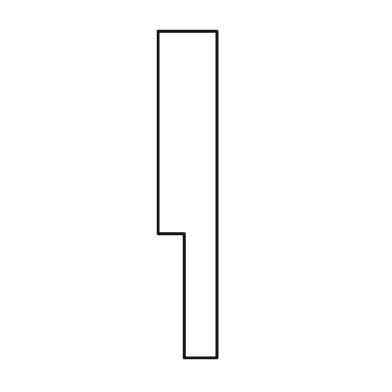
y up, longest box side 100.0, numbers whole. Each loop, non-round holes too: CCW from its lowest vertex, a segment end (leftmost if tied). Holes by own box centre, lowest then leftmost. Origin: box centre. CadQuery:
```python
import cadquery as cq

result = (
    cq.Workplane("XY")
    .moveTo(-1.0, -50.0)
    .lineTo(9.0, -50.0)
    .lineTo(9.0, 50.0)
    .lineTo(-9.0, 50.0)
    .lineTo(-9.0, -12.0)
    .lineTo(-1.0, -12.0)
    .close()
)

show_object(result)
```